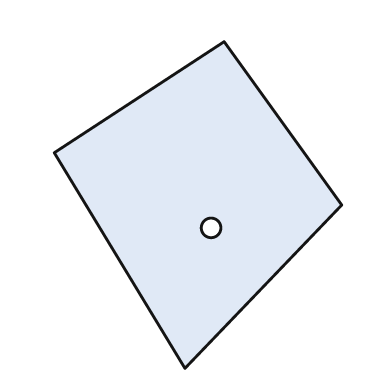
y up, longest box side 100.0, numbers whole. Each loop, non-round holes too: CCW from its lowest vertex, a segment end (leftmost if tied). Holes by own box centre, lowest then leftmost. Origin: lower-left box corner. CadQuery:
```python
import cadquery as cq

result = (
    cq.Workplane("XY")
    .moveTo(40.0, 0.0)
    .lineTo(88.0, 50.0)
    .lineTo(52.0, 100.0)
    .lineTo(0.0, 66.0)
    .close()
    .moveTo(48.0, 43.0)
    .circle(3.0)
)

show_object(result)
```